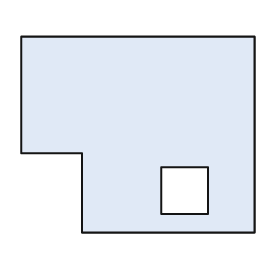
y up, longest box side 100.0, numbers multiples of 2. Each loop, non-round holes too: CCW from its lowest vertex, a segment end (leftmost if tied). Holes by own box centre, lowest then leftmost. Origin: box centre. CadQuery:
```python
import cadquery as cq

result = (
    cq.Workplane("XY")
    .moveTo(-24.0, -42.0)
    .lineTo(50.0, -42.0)
    .lineTo(50.0, 42.0)
    .lineTo(-50.0, 42.0)
    .lineTo(-50.0, -8.0)
    .lineTo(-24.0, -8.0)
    .close()
    .moveTo(10.0, -34.0)
    .lineTo(30.0, -34.0)
    .lineTo(30.0, -14.0)
    .lineTo(10.0, -14.0)
    .close()
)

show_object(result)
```